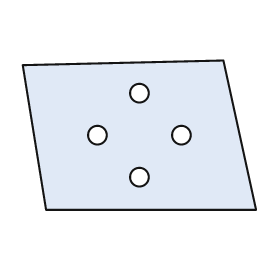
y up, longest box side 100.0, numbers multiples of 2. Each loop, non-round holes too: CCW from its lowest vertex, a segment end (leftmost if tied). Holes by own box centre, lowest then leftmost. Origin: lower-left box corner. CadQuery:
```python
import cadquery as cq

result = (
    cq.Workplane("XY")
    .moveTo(10.0, 0.0)
    .lineTo(100.0, 0.0)
    .lineTo(86.0, 64.0)
    .lineTo(0.0, 62.0)
    .close()
    .moveTo(50.0, 14.0)
    .circle(4.0)
    .moveTo(32.0, 32.0)
    .circle(4.0)
    .moveTo(68.0, 32.0)
    .circle(4.0)
    .moveTo(50.0, 50.0)
    .circle(4.0)
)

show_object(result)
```